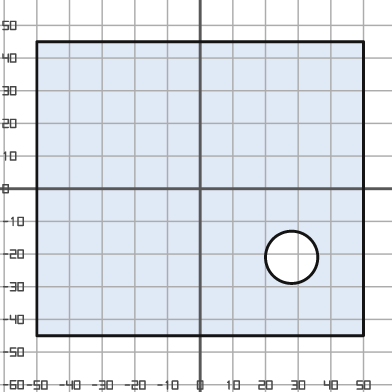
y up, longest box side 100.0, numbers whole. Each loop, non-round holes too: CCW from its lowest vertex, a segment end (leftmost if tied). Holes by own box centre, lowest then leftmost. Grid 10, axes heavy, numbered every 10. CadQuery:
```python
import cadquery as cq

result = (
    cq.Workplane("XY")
    .moveTo(-50.0, -45.0)
    .lineTo(50.0, -45.0)
    .lineTo(50.0, 45.0)
    .lineTo(-50.0, 45.0)
    .close()
    .moveTo(28.0, -21.0)
    .circle(8.0)
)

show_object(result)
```